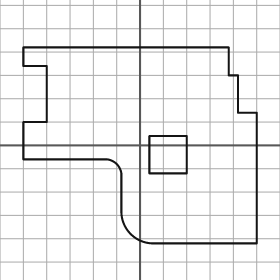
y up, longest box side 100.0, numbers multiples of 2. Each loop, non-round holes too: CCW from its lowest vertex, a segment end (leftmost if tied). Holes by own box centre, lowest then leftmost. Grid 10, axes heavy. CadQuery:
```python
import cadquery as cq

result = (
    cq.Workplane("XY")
    .moveTo(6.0, -42.0)
    .lineTo(50.0, -42.0)
    .lineTo(50.0, 14.0)
    .lineTo(42.0, 14.0)
    .lineTo(42.0, 30.0)
    .lineTo(38.0, 30.0)
    .lineTo(38.0, 42.0)
    .lineTo(-50.0, 42.0)
    .lineTo(-50.0, 34.0)
    .lineTo(-40.0, 34.0)
    .lineTo(-40.0, 10.0)
    .lineTo(-50.0, 10.0)
    .lineTo(-50.0, -6.0)
    .lineTo(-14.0, -6.0)
    .threePointArc((-10.0, -8.0), (-8.0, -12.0))
    .lineTo(-8.0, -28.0)
    .threePointArc((-4.0, -38.0), (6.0, -42.0))
    .close()
    .moveTo(4.0, -12.0)
    .lineTo(20.0, -12.0)
    .lineTo(20.0, 4.0)
    .lineTo(4.0, 4.0)
    .close()
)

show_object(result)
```